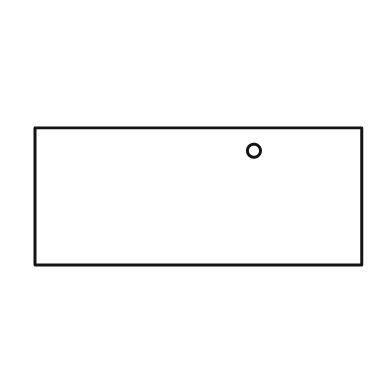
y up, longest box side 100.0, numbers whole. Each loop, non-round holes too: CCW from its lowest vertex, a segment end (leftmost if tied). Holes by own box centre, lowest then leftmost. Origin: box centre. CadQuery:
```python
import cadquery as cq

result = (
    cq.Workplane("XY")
    .moveTo(-50.0, -21.0)
    .lineTo(50.0, -21.0)
    .lineTo(50.0, 21.0)
    .lineTo(-50.0, 21.0)
    .close()
    .moveTo(17.0, 14.0)
    .circle(2.0)
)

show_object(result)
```